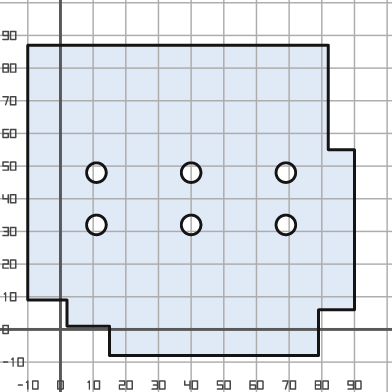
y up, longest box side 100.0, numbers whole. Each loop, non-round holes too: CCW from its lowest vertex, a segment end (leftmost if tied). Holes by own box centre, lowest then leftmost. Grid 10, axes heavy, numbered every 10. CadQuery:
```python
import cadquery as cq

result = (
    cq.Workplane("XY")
    .moveTo(15.0, -8.0)
    .lineTo(79.0, -8.0)
    .lineTo(79.0, 6.0)
    .lineTo(90.0, 6.0)
    .lineTo(90.0, 55.0)
    .lineTo(82.0, 55.0)
    .lineTo(82.0, 87.0)
    .lineTo(-10.0, 87.0)
    .lineTo(-10.0, 9.0)
    .lineTo(2.0, 9.0)
    .lineTo(2.0, 1.0)
    .lineTo(15.0, 1.0)
    .close()
    .moveTo(11.0, 32.0)
    .circle(3.0)
    .moveTo(40.0, 32.0)
    .circle(3.0)
    .moveTo(69.0, 32.0)
    .circle(3.0)
    .moveTo(11.0, 48.0)
    .circle(3.0)
    .moveTo(40.0, 48.0)
    .circle(3.0)
    .moveTo(69.0, 48.0)
    .circle(3.0)
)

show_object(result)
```